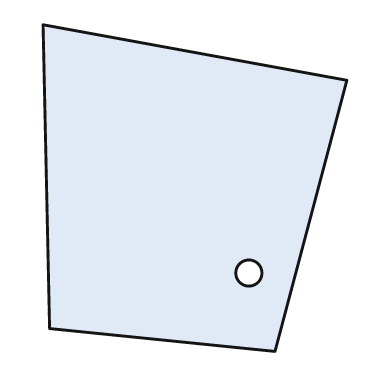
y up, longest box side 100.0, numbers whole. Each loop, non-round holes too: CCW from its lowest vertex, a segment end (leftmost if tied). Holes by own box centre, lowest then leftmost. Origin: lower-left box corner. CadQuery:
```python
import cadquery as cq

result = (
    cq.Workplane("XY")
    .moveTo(71.0, 0.0)
    .lineTo(93.0, 83.0)
    .lineTo(0.0, 100.0)
    .lineTo(2.0, 7.0)
    .close()
    .moveTo(63.0, 24.0)
    .circle(4.0)
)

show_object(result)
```